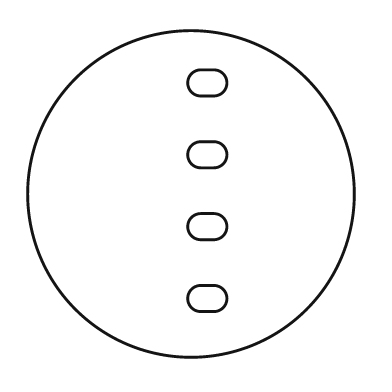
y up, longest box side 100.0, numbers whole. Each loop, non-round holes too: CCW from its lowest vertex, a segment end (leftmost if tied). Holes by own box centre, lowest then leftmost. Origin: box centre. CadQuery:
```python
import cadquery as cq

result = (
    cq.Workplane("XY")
    .moveTo(0.0, 0.0)
    .circle(50.0)
    .moveTo(3.0, -36.0)
    .lineTo(7.0, -36.0)
    .threePointArc((11.0, -32.0), (7.0, -28.0))
    .lineTo(3.0, -28.0)
    .threePointArc((-1.0, -32.0), (3.0, -36.0))
    .close()
    .moveTo(3.0, -14.0)
    .lineTo(7.0, -14.0)
    .threePointArc((11.0, -10.0), (7.0, -6.0))
    .lineTo(3.0, -6.0)
    .threePointArc((-1.0, -10.0), (3.0, -14.0))
    .close()
    .moveTo(3.0, 8.0)
    .lineTo(7.0, 8.0)
    .threePointArc((11.0, 12.0), (7.0, 16.0))
    .lineTo(3.0, 16.0)
    .threePointArc((-1.0, 12.0), (3.0, 8.0))
    .close()
    .moveTo(3.0, 30.0)
    .lineTo(7.0, 30.0)
    .threePointArc((11.0, 34.0), (7.0, 38.0))
    .lineTo(3.0, 38.0)
    .threePointArc((-1.0, 34.0), (3.0, 30.0))
    .close()
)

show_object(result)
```